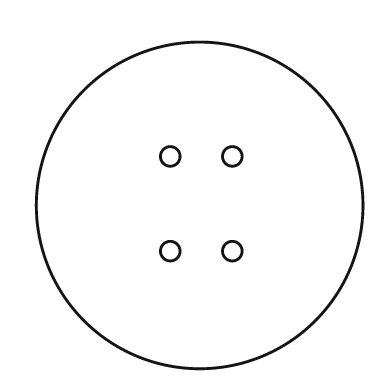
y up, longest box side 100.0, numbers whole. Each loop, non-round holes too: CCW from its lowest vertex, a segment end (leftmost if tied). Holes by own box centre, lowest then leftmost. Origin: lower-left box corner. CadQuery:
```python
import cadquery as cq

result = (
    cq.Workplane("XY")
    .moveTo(50.0, 50.0)
    .circle(50.0)
    .moveTo(41.0, 36.0)
    .circle(3.0)
    .moveTo(60.0, 36.0)
    .circle(3.0)
    .moveTo(41.0, 65.0)
    .circle(3.0)
    .moveTo(60.0, 65.0)
    .circle(3.0)
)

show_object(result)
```